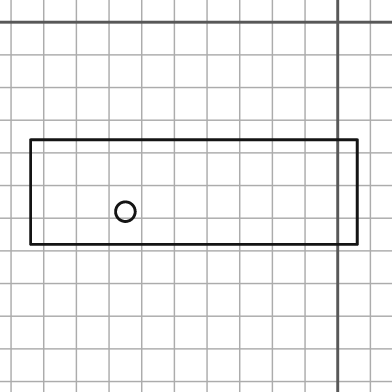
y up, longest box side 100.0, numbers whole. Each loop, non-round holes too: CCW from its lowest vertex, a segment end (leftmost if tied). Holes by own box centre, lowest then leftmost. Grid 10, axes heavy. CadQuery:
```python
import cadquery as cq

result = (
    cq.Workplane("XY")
    .moveTo(-94.0, -68.0)
    .lineTo(6.0, -68.0)
    .lineTo(6.0, -36.0)
    .lineTo(-94.0, -36.0)
    .close()
    .moveTo(-65.0, -58.0)
    .circle(3.0)
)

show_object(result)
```